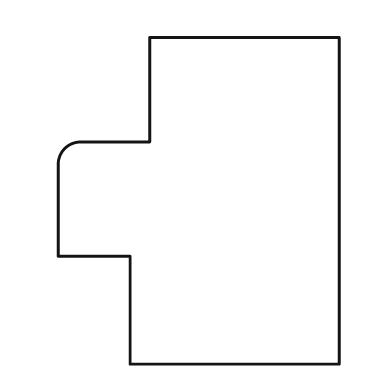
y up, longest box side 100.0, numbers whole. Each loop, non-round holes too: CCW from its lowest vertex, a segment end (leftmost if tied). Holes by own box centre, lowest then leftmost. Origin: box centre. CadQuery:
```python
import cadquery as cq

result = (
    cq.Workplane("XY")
    .moveTo(-21.0, -50.0)
    .lineTo(43.0, -50.0)
    .lineTo(43.0, 50.0)
    .lineTo(-15.0, 50.0)
    .lineTo(-15.0, 18.0)
    .lineTo(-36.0, 18.0)
    .threePointArc((-41.0, 16.0), (-43.0, 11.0))
    .lineTo(-43.0, -17.0)
    .lineTo(-21.0, -17.0)
    .close()
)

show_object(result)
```